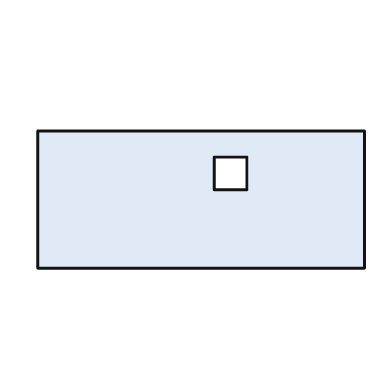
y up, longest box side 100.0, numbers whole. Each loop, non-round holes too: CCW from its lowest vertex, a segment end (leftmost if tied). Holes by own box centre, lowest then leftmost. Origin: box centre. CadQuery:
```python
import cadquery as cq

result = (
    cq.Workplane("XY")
    .moveTo(-50.0, -21.0)
    .lineTo(50.0, -21.0)
    .lineTo(50.0, 21.0)
    .lineTo(-50.0, 21.0)
    .close()
    .moveTo(4.0, 3.0)
    .lineTo(14.0, 3.0)
    .lineTo(14.0, 13.0)
    .lineTo(4.0, 13.0)
    .close()
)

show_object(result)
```